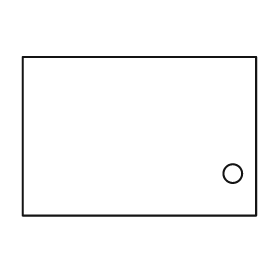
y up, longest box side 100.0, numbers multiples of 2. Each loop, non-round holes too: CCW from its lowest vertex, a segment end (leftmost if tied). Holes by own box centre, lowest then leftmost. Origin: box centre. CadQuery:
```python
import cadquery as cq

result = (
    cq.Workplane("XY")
    .moveTo(-50.0, -34.0)
    .lineTo(50.0, -34.0)
    .lineTo(50.0, 34.0)
    .lineTo(-50.0, 34.0)
    .close()
    .moveTo(40.0, -16.0)
    .circle(4.0)
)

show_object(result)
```